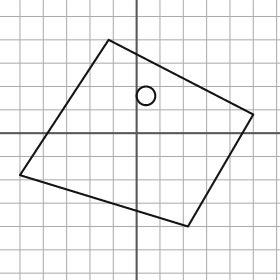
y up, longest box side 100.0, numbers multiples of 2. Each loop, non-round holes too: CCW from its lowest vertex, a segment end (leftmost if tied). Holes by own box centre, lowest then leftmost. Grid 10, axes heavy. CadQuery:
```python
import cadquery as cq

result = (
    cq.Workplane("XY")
    .moveTo(22.0, -40.0)
    .lineTo(50.0, 8.0)
    .lineTo(-12.0, 40.0)
    .lineTo(-50.0, -18.0)
    .close()
    .moveTo(4.0, 16.0)
    .circle(4.0)
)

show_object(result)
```